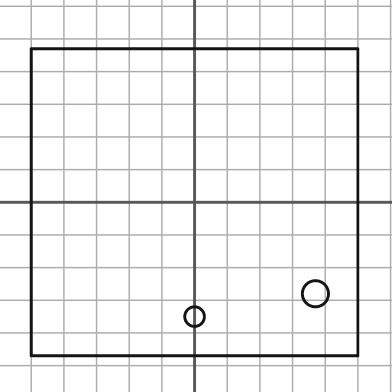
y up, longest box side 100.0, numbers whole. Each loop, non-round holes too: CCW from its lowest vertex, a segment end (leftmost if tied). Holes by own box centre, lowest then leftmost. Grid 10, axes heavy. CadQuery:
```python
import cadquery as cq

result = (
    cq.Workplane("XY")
    .moveTo(-50.0, -47.0)
    .lineTo(50.0, -47.0)
    .lineTo(50.0, 47.0)
    .lineTo(-50.0, 47.0)
    .close()
    .moveTo(0.0, -35.0)
    .circle(3.0)
    .moveTo(37.0, -28.0)
    .circle(4.0)
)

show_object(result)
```